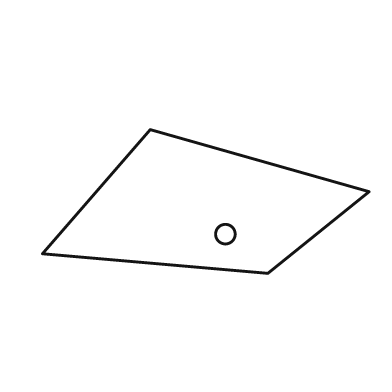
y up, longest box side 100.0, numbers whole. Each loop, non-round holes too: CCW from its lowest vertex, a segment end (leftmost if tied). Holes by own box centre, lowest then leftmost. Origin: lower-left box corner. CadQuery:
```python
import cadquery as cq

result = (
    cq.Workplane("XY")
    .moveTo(69.0, 0.0)
    .lineTo(100.0, 25.0)
    .lineTo(33.0, 44.0)
    .lineTo(0.0, 6.0)
    .close()
    .moveTo(56.0, 12.0)
    .circle(3.0)
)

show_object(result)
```